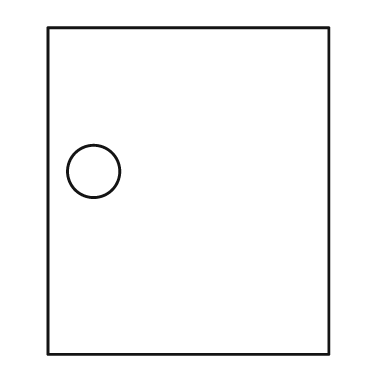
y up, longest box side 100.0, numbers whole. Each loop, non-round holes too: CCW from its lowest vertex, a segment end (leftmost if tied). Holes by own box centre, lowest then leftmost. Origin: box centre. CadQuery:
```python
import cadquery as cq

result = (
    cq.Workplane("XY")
    .moveTo(-43.0, -50.0)
    .lineTo(43.0, -50.0)
    .lineTo(43.0, 50.0)
    .lineTo(-43.0, 50.0)
    .close()
    .moveTo(-29.0, 6.0)
    .circle(8.0)
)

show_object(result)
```